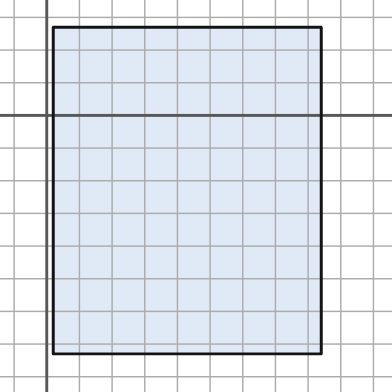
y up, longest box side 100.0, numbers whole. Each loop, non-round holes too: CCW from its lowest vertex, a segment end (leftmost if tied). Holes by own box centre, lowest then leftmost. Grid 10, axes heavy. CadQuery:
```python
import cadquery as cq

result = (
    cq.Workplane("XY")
    .moveTo(2.0, -73.0)
    .lineTo(84.0, -73.0)
    .lineTo(84.0, 27.0)
    .lineTo(2.0, 27.0)
    .close()
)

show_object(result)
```